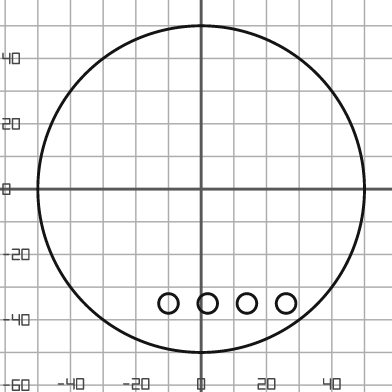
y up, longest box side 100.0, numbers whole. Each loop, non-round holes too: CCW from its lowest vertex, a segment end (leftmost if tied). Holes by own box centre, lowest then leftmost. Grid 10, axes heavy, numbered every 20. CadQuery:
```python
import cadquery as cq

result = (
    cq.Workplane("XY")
    .moveTo(0.0, 0.0)
    .circle(50.0)
    .moveTo(-10.0, -35.0)
    .circle(3.0)
    .moveTo(2.0, -35.0)
    .circle(3.0)
    .moveTo(14.0, -35.0)
    .circle(3.0)
    .moveTo(26.0, -35.0)
    .circle(3.0)
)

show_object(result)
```